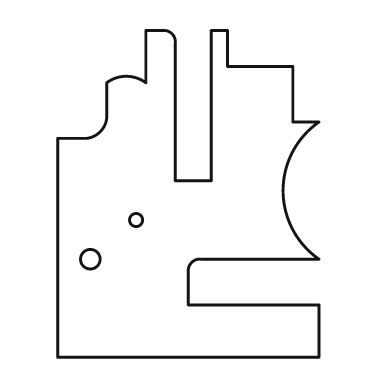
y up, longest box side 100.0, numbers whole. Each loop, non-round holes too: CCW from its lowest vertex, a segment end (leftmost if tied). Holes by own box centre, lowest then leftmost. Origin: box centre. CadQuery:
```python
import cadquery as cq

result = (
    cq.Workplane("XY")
    .moveTo(-40.0, -50.0)
    .lineTo(40.0, -50.0)
    .lineTo(40.0, -34.0)
    .lineTo(0.0, -34.0)
    .lineTo(0.0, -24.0)
    .threePointArc((1.0, -21.0), (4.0, -20.0))
    .lineTo(40.0, -20.0)
    .threePointArc((29.0, 1.0), (40.0, 22.0))
    .lineTo(32.0, 22.0)
    .lineTo(32.0, 39.0)
    .lineTo(12.0, 39.0)
    .lineTo(12.0, 50.0)
    .lineTo(7.0, 50.0)
    .lineTo(7.0, 4.0)
    .lineTo(-4.0, 4.0)
    .lineTo(-4.0, 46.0)
    .threePointArc((-5.0, 49.0), (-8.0, 50.0))
    .lineTo(-13.0, 50.0)
    .lineTo(-13.0, 34.0)
    .threePointArc((-19.0, 36.0), (-25.0, 34.0))
    .lineTo(-25.0, 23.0)
    .threePointArc((-27.0, 19.0), (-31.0, 17.0))
    .lineTo(-40.0, 17.0)
    .close()
    .moveTo(-30.0, -20.0)
    .circle(3.0)
    .moveTo(-16.0, -8.0)
    .circle(2.0)
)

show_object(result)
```